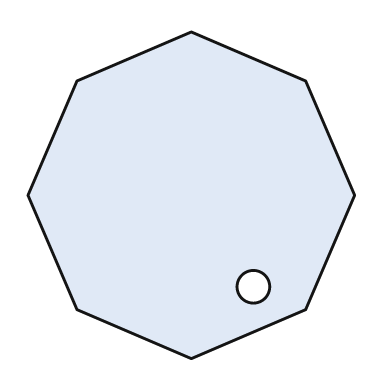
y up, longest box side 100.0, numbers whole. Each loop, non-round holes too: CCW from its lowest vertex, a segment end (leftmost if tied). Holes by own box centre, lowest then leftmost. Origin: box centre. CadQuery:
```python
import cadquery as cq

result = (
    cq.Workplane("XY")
    .moveTo(0.0, -50.0)
    .lineTo(35.0, -35.0)
    .lineTo(50.0, 0.0)
    .lineTo(35.0, 35.0)
    .lineTo(0.0, 50.0)
    .lineTo(-35.0, 35.0)
    .lineTo(-50.0, 0.0)
    .lineTo(-35.0, -35.0)
    .close()
    .moveTo(19.0, -28.0)
    .circle(5.0)
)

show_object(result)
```